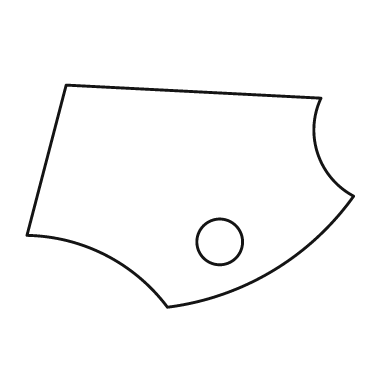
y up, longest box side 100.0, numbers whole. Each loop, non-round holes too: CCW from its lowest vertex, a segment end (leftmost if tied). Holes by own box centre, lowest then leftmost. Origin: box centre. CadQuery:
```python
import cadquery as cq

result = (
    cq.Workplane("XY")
    .moveTo(-7.0, -34.0)
    .threePointArc((25.0, -23.0), (50.0, 0.0))
    .threePointArc((39.0, 13.0), (40.0, 30.0))
    .lineTo(-38.0, 34.0)
    .lineTo(-50.0, -12.0)
    .threePointArc((-26.0, -18.0), (-7.0, -34.0))
    .close()
    .moveTo(9.0, -14.0)
    .circle(7.0)
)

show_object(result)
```